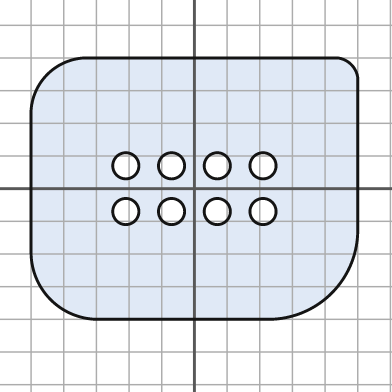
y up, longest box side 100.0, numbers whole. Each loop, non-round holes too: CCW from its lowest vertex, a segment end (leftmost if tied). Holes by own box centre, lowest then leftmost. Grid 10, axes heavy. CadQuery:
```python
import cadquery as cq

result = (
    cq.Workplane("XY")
    .moveTo(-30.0, -40.0)
    .lineTo(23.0, -40.0)
    .threePointArc((42.0, -32.0), (50.0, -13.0))
    .lineTo(50.0, 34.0)
    .threePointArc((48.0, 38.0), (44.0, 40.0))
    .lineTo(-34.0, 40.0)
    .threePointArc((-45.0, 35.0), (-50.0, 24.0))
    .lineTo(-50.0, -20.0)
    .threePointArc((-44.0, -34.0), (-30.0, -40.0))
    .close()
    .moveTo(-21.0, -7.0)
    .circle(4.0)
    .moveTo(-7.0, -7.0)
    .circle(4.0)
    .moveTo(7.0, -7.0)
    .circle(4.0)
    .moveTo(21.0, -7.0)
    .circle(4.0)
    .moveTo(-21.0, 7.0)
    .circle(4.0)
    .moveTo(-7.0, 7.0)
    .circle(4.0)
    .moveTo(7.0, 7.0)
    .circle(4.0)
    .moveTo(21.0, 7.0)
    .circle(4.0)
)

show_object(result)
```